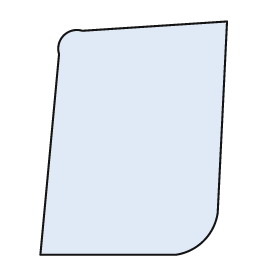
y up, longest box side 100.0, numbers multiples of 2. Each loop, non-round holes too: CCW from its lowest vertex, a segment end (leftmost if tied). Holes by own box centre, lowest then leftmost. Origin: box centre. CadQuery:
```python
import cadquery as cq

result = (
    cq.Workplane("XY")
    .moveTo(-40.0, -50.0)
    .lineTo(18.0, -50.0)
    .threePointArc((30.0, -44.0), (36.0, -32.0))
    .lineTo(40.0, 50.0)
    .lineTo(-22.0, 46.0)
    .threePointArc((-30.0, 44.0), (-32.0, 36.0))
    .close()
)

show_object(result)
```